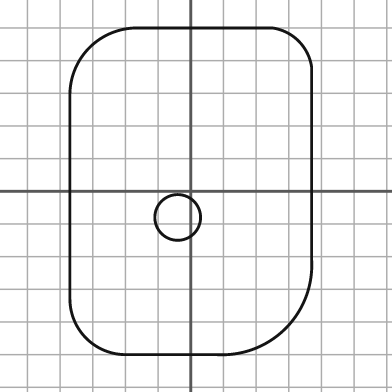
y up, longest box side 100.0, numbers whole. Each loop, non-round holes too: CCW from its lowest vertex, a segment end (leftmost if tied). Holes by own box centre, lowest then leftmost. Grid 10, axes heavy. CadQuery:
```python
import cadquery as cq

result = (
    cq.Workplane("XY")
    .moveTo(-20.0, -50.0)
    .lineTo(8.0, -50.0)
    .threePointArc((29.0, -42.0), (37.0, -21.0))
    .lineTo(37.0, 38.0)
    .threePointArc((33.0, 46.0), (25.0, 50.0))
    .lineTo(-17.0, 50.0)
    .threePointArc((-31.0, 44.0), (-37.0, 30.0))
    .lineTo(-37.0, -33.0)
    .threePointArc((-32.0, -45.0), (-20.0, -50.0))
    .close()
    .moveTo(-4.0, -8.0)
    .circle(7.0)
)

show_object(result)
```